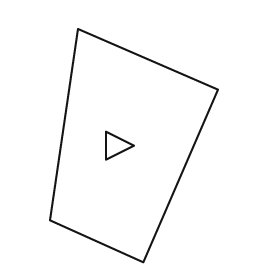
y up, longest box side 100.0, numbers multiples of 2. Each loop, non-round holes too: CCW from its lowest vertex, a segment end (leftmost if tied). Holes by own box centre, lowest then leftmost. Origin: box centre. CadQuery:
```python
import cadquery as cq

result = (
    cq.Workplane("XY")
    .moveTo(4.0, -50.0)
    .lineTo(36.0, 24.0)
    .lineTo(-24.0, 50.0)
    .lineTo(-36.0, -32.0)
    .close()
    .moveTo(-12.0, -6.0)
    .lineTo(0.0, 0.0)
    .lineTo(-12.0, 6.0)
    .close()
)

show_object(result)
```